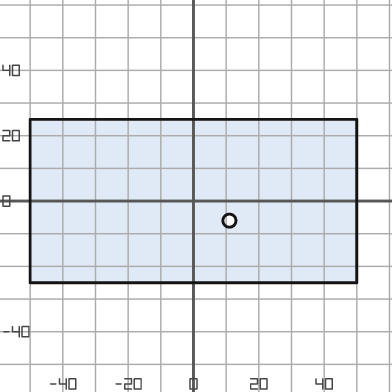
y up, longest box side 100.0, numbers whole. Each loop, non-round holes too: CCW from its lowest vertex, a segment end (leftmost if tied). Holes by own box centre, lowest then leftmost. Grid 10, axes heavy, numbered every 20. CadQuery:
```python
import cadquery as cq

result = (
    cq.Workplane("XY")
    .moveTo(-50.0, -25.0)
    .lineTo(50.0, -25.0)
    .lineTo(50.0, 25.0)
    .lineTo(-50.0, 25.0)
    .close()
    .moveTo(11.0, -6.0)
    .circle(2.0)
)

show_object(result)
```